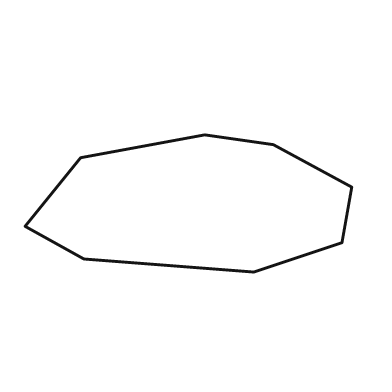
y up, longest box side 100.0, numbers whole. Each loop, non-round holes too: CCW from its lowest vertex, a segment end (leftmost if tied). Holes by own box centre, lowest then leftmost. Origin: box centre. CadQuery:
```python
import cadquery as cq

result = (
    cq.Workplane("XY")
    .moveTo(20.0, -21.0)
    .lineTo(47.0, -12.0)
    .lineTo(50.0, 5.0)
    .lineTo(26.0, 18.0)
    .lineTo(5.0, 21.0)
    .lineTo(-33.0, 14.0)
    .lineTo(-50.0, -7.0)
    .lineTo(-32.0, -17.0)
    .close()
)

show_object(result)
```